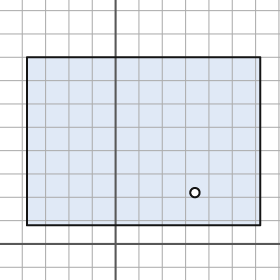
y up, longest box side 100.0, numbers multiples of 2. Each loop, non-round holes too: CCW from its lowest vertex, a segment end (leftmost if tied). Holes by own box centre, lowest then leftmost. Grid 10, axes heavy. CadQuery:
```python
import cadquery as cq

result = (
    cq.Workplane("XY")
    .moveTo(-38.0, 8.0)
    .lineTo(62.0, 8.0)
    .lineTo(62.0, 80.0)
    .lineTo(-38.0, 80.0)
    .close()
    .moveTo(34.0, 22.0)
    .circle(2.0)
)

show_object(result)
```